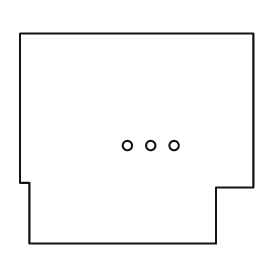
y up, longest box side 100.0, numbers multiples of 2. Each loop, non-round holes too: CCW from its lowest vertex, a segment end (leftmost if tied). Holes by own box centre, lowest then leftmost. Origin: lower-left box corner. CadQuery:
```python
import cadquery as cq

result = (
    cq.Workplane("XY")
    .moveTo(4.0, 0.0)
    .lineTo(84.0, 0.0)
    .lineTo(84.0, 24.0)
    .lineTo(100.0, 24.0)
    .lineTo(100.0, 90.0)
    .lineTo(0.0, 90.0)
    .lineTo(0.0, 26.0)
    .lineTo(4.0, 26.0)
    .close()
    .moveTo(46.0, 42.0)
    .circle(2.0)
    .moveTo(56.0, 42.0)
    .circle(2.0)
    .moveTo(66.0, 42.0)
    .circle(2.0)
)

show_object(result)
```